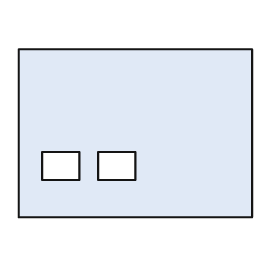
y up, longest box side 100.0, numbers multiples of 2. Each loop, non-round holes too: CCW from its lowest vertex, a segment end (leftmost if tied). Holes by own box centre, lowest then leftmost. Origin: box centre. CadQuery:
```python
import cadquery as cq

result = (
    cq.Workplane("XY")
    .moveTo(-50.0, -36.0)
    .lineTo(50.0, -36.0)
    .lineTo(50.0, 36.0)
    .lineTo(-50.0, 36.0)
    .close()
    .moveTo(-40.0, -20.0)
    .lineTo(-24.0, -20.0)
    .lineTo(-24.0, -8.0)
    .lineTo(-40.0, -8.0)
    .close()
    .moveTo(-16.0, -20.0)
    .lineTo(0.0, -20.0)
    .lineTo(0.0, -8.0)
    .lineTo(-16.0, -8.0)
    .close()
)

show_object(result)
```